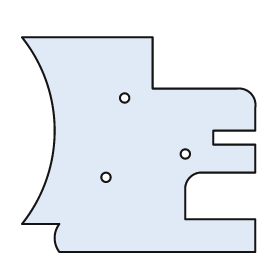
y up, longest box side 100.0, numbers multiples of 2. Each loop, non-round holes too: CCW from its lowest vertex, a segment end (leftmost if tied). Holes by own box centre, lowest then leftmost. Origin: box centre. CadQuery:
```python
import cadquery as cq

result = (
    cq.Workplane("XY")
    .moveTo(-34.0, -46.0)
    .lineTo(50.0, -46.0)
    .lineTo(50.0, -32.0)
    .lineTo(20.0, -32.0)
    .lineTo(20.0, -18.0)
    .threePointArc((22.0, -14.0), (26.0, -12.0))
    .lineTo(50.0, -12.0)
    .lineTo(50.0, 0.0)
    .lineTo(32.0, 0.0)
    .lineTo(32.0, 6.0)
    .lineTo(50.0, 6.0)
    .lineTo(50.0, 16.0)
    .threePointArc((48.0, 22.0), (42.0, 24.0))
    .lineTo(6.0, 24.0)
    .lineTo(6.0, 46.0)
    .lineTo(-50.0, 46.0)
    .threePointArc((-36.0, 6.0), (-50.0, -34.0))
    .lineTo(-34.0, -34.0)
    .threePointArc((-36.0, -40.0), (-34.0, -46.0))
    .close()
    .moveTo(-14.0, -14.0)
    .circle(2.0)
    .moveTo(20.0, -4.0)
    .circle(2.0)
    .moveTo(-6.0, 20.0)
    .circle(2.0)
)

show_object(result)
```